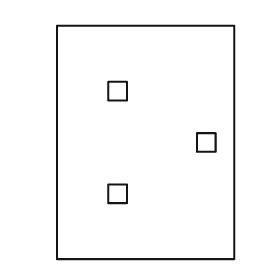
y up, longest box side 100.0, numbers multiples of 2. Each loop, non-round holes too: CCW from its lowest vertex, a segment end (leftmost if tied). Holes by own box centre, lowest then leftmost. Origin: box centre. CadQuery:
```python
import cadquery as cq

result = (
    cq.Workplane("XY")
    .moveTo(-38.0, -50.0)
    .lineTo(38.0, -50.0)
    .lineTo(38.0, 50.0)
    .lineTo(-38.0, 50.0)
    .close()
    .moveTo(-16.0, -26.0)
    .lineTo(-8.0, -26.0)
    .lineTo(-8.0, -18.0)
    .lineTo(-16.0, -18.0)
    .close()
    .moveTo(22.0, -4.0)
    .lineTo(30.0, -4.0)
    .lineTo(30.0, 4.0)
    .lineTo(22.0, 4.0)
    .close()
    .moveTo(-16.0, 18.0)
    .lineTo(-8.0, 18.0)
    .lineTo(-8.0, 26.0)
    .lineTo(-16.0, 26.0)
    .close()
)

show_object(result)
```